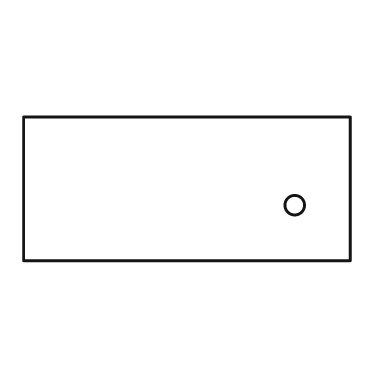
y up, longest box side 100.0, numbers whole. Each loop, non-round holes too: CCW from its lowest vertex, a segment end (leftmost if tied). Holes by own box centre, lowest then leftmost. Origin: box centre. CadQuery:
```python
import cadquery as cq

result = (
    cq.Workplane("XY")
    .moveTo(-50.0, -22.0)
    .lineTo(50.0, -22.0)
    .lineTo(50.0, 22.0)
    .lineTo(-50.0, 22.0)
    .close()
    .moveTo(33.0, -5.0)
    .circle(3.0)
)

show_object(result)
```